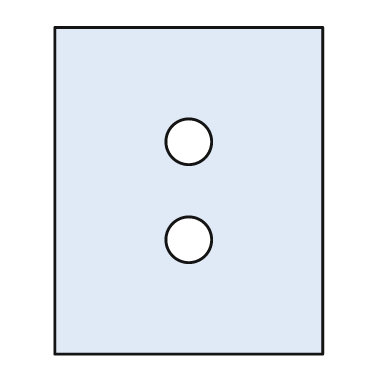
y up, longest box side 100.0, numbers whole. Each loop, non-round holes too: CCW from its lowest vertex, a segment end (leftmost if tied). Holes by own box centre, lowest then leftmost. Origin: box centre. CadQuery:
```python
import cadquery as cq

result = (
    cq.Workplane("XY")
    .moveTo(-41.0, -50.0)
    .lineTo(41.0, -50.0)
    .lineTo(41.0, 50.0)
    .lineTo(-41.0, 50.0)
    .close()
    .moveTo(0.0, -15.0)
    .circle(7.0)
    .moveTo(0.0, 15.0)
    .circle(7.0)
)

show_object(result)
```